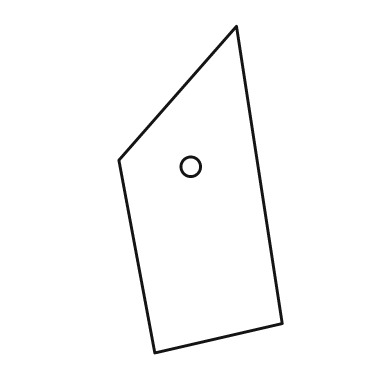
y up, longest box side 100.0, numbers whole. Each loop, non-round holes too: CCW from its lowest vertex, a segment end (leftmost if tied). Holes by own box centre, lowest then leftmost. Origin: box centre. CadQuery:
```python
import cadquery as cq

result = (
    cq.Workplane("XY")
    .moveTo(-14.0, -50.0)
    .lineTo(25.0, -41.0)
    .lineTo(11.0, 50.0)
    .lineTo(-25.0, 9.0)
    .close()
    .moveTo(-3.0, 7.0)
    .circle(3.0)
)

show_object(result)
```